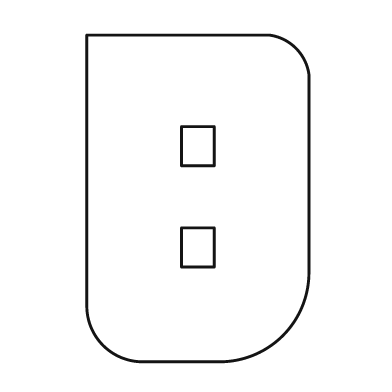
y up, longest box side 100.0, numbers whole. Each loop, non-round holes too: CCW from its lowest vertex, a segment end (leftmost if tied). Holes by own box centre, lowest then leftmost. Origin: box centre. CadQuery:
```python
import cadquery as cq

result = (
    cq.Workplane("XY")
    .moveTo(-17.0, -50.0)
    .lineTo(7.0, -50.0)
    .threePointArc((26.0, -42.0), (34.0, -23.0))
    .lineTo(34.0, 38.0)
    .threePointArc((30.0, 46.0), (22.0, 50.0))
    .lineTo(-34.0, 50.0)
    .lineTo(-34.0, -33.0)
    .threePointArc((-29.0, -45.0), (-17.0, -50.0))
    .close()
    .moveTo(-5.0, -21.0)
    .lineTo(5.0, -21.0)
    .lineTo(5.0, -9.0)
    .lineTo(-5.0, -9.0)
    .close()
    .moveTo(-5.0, 10.0)
    .lineTo(5.0, 10.0)
    .lineTo(5.0, 22.0)
    .lineTo(-5.0, 22.0)
    .close()
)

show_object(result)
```